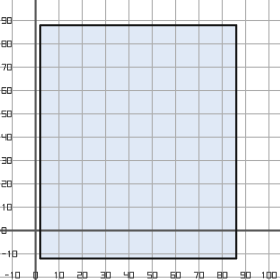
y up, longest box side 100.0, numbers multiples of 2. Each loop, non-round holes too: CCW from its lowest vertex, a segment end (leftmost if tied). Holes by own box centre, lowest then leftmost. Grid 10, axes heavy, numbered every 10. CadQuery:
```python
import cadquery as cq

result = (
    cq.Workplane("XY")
    .moveTo(2.0, -12.0)
    .lineTo(86.0, -12.0)
    .lineTo(86.0, 88.0)
    .lineTo(2.0, 88.0)
    .close()
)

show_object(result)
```